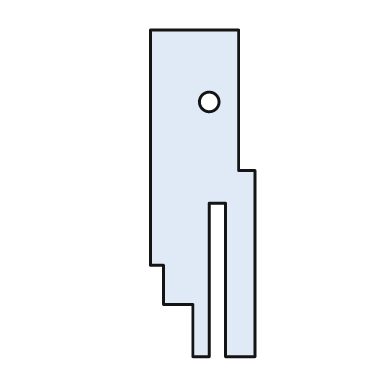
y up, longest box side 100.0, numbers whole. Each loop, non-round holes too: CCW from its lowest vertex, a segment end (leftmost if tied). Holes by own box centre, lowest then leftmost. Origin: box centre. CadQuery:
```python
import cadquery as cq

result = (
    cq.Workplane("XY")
    .moveTo(-3.0, -50.0)
    .lineTo(2.0, -50.0)
    .lineTo(2.0, -3.0)
    .lineTo(7.0, -3.0)
    .lineTo(7.0, -50.0)
    .lineTo(16.0, -50.0)
    .lineTo(16.0, 7.0)
    .lineTo(11.0, 7.0)
    .lineTo(11.0, 50.0)
    .lineTo(-16.0, 50.0)
    .lineTo(-16.0, -22.0)
    .lineTo(-12.0, -22.0)
    .lineTo(-12.0, -34.0)
    .lineTo(-3.0, -34.0)
    .close()
    .moveTo(2.0, 28.0)
    .circle(3.0)
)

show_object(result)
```